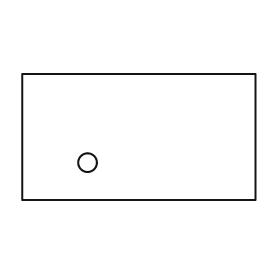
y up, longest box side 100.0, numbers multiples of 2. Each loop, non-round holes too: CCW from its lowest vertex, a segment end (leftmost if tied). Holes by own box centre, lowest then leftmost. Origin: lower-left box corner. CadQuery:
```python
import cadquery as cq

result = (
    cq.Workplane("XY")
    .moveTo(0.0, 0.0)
    .lineTo(100.0, 0.0)
    .lineTo(100.0, 54.0)
    .lineTo(0.0, 54.0)
    .close()
    .moveTo(28.0, 16.0)
    .circle(4.0)
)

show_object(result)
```